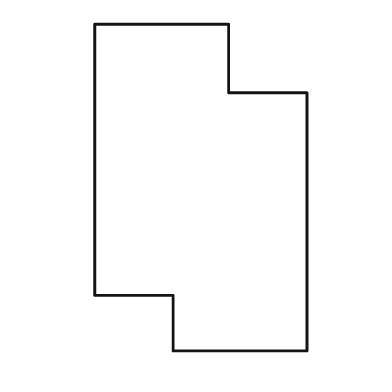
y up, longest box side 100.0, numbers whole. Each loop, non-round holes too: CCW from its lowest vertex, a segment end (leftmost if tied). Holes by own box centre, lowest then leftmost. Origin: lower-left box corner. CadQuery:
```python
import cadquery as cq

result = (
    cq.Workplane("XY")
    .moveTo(24.0, 0.0)
    .lineTo(65.0, 0.0)
    .lineTo(65.0, 79.0)
    .lineTo(41.0, 79.0)
    .lineTo(41.0, 100.0)
    .lineTo(0.0, 100.0)
    .lineTo(0.0, 17.0)
    .lineTo(24.0, 17.0)
    .close()
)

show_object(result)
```